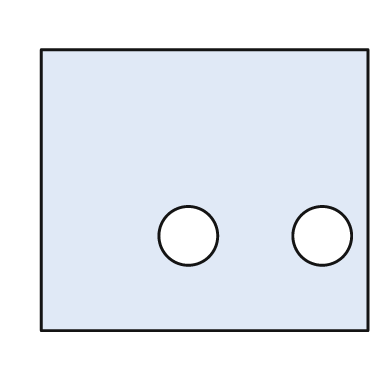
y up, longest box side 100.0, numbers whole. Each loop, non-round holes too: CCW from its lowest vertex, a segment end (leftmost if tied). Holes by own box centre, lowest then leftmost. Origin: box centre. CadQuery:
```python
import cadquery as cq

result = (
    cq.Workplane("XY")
    .moveTo(-50.0, -43.0)
    .lineTo(50.0, -43.0)
    .lineTo(50.0, 43.0)
    .lineTo(-50.0, 43.0)
    .close()
    .moveTo(-5.0, -14.0)
    .circle(9.0)
    .moveTo(36.0, -14.0)
    .circle(9.0)
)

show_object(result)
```